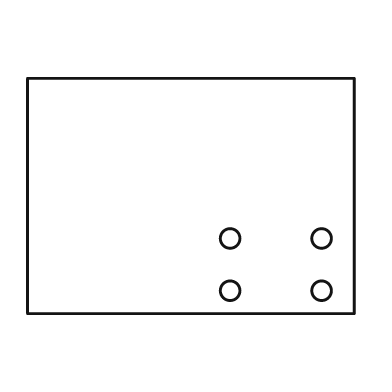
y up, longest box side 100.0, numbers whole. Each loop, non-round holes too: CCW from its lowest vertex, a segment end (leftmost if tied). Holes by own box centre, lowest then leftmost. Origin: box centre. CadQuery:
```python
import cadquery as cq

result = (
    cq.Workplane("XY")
    .moveTo(-50.0, -36.0)
    .lineTo(50.0, -36.0)
    .lineTo(50.0, 36.0)
    .lineTo(-50.0, 36.0)
    .close()
    .moveTo(12.0, -29.0)
    .circle(3.0)
    .moveTo(40.0, -29.0)
    .circle(3.0)
    .moveTo(12.0, -13.0)
    .circle(3.0)
    .moveTo(40.0, -13.0)
    .circle(3.0)
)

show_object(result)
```